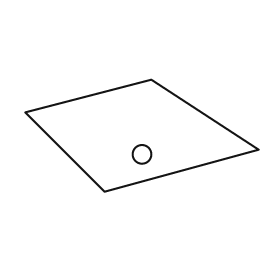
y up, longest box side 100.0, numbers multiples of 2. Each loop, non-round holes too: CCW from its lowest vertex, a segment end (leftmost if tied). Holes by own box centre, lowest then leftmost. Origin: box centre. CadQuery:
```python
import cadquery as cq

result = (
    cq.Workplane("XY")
    .moveTo(-16.0, -24.0)
    .lineTo(50.0, -6.0)
    .lineTo(4.0, 24.0)
    .lineTo(-50.0, 10.0)
    .close()
    .moveTo(0.0, -8.0)
    .circle(4.0)
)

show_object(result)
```